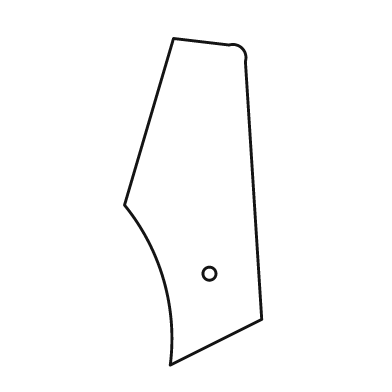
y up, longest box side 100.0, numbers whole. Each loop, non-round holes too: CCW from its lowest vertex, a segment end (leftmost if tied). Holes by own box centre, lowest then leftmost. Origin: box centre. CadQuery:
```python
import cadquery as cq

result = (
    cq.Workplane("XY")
    .moveTo(-7.0, -50.0)
    .lineTo(21.0, -36.0)
    .lineTo(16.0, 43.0)
    .threePointArc((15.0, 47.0), (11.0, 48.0))
    .lineTo(-6.0, 50.0)
    .lineTo(-21.0, -1.0)
    .threePointArc((-9.0, -24.0), (-7.0, -50.0))
    .close()
    .moveTo(5.0, -22.0)
    .circle(2.0)
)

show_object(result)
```